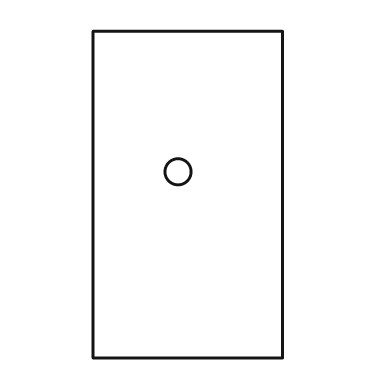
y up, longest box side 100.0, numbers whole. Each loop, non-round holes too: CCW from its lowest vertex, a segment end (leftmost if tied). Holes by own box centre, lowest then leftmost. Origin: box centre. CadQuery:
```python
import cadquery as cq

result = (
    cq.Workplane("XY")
    .moveTo(-29.0, -50.0)
    .lineTo(29.0, -50.0)
    .lineTo(29.0, 50.0)
    .lineTo(-29.0, 50.0)
    .close()
    .moveTo(-3.0, 7.0)
    .circle(4.0)
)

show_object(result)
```